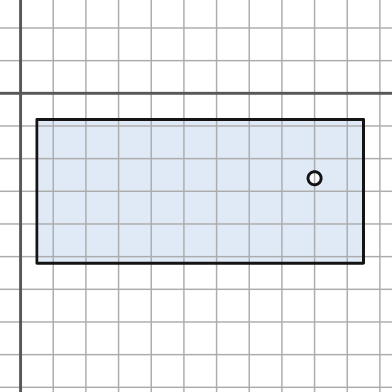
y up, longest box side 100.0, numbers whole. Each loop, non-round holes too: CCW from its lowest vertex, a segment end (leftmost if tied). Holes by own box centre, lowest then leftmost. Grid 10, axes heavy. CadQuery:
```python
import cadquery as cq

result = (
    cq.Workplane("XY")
    .moveTo(5.0, -52.0)
    .lineTo(105.0, -52.0)
    .lineTo(105.0, -8.0)
    .lineTo(5.0, -8.0)
    .close()
    .moveTo(90.0, -26.0)
    .circle(2.0)
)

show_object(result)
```